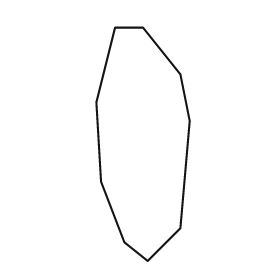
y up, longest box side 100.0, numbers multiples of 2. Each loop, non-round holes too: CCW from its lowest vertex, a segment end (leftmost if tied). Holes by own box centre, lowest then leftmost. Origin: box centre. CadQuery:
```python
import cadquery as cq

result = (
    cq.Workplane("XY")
    .moveTo(2.0, -50.0)
    .lineTo(16.0, -36.0)
    .lineTo(20.0, 10.0)
    .lineTo(16.0, 30.0)
    .lineTo(0.0, 50.0)
    .lineTo(-12.0, 50.0)
    .lineTo(-20.0, 18.0)
    .lineTo(-18.0, -16.0)
    .lineTo(-8.0, -42.0)
    .close()
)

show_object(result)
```